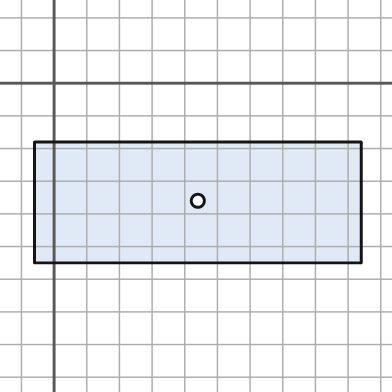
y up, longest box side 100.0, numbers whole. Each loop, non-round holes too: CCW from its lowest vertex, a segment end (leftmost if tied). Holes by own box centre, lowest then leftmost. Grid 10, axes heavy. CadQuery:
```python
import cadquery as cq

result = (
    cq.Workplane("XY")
    .moveTo(-6.0, -55.0)
    .lineTo(94.0, -55.0)
    .lineTo(94.0, -18.0)
    .lineTo(-6.0, -18.0)
    .close()
    .moveTo(44.0, -36.0)
    .circle(2.0)
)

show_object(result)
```